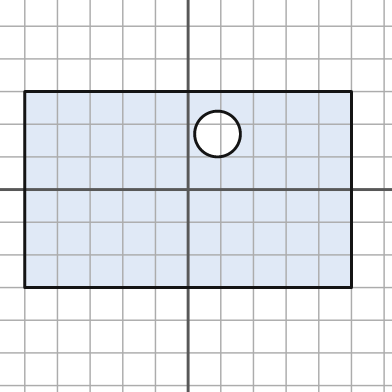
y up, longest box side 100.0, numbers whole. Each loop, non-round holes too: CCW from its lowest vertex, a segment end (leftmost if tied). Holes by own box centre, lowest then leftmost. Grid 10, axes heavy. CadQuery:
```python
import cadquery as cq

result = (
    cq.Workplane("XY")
    .moveTo(-50.0, -30.0)
    .lineTo(50.0, -30.0)
    .lineTo(50.0, 30.0)
    .lineTo(-50.0, 30.0)
    .close()
    .moveTo(9.0, 17.0)
    .circle(7.0)
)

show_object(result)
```